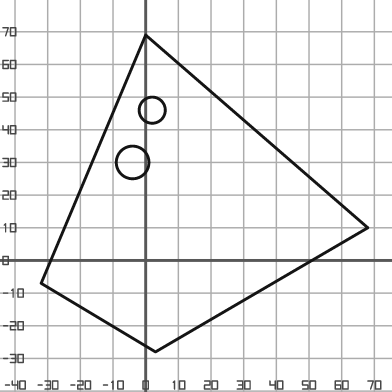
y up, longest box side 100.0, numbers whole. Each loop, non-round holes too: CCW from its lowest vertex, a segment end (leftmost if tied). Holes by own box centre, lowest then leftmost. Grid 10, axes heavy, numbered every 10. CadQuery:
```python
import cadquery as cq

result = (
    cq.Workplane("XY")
    .moveTo(3.0, -28.0)
    .lineTo(68.0, 10.0)
    .lineTo(0.0, 69.0)
    .lineTo(-32.0, -7.0)
    .close()
    .moveTo(-4.0, 30.0)
    .circle(5.0)
    .moveTo(2.0, 46.0)
    .circle(4.0)
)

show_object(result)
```